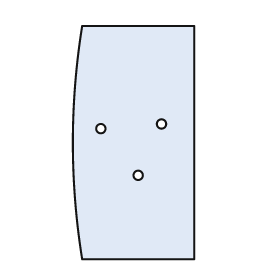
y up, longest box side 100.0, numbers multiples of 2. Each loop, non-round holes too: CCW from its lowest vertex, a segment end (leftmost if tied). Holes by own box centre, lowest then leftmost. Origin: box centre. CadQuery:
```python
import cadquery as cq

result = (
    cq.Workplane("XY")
    .moveTo(-22.0, -50.0)
    .lineTo(26.0, -50.0)
    .lineTo(26.0, 50.0)
    .lineTo(-22.0, 50.0)
    .threePointArc((-26.0, 0.0), (-22.0, -50.0))
    .close()
    .moveTo(2.0, -14.0)
    .circle(2.0)
    .moveTo(-14.0, 6.0)
    .circle(2.0)
    .moveTo(12.0, 8.0)
    .circle(2.0)
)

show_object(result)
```